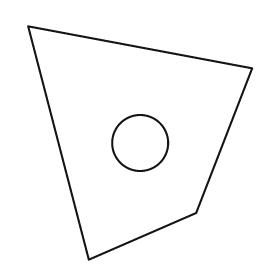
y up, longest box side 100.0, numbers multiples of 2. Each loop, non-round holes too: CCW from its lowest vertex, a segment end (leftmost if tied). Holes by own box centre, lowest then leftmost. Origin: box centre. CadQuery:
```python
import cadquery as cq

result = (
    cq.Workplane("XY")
    .moveTo(-22.0, -50.0)
    .lineTo(24.0, -30.0)
    .lineTo(48.0, 32.0)
    .lineTo(-48.0, 50.0)
    .close()
    .moveTo(0.0, 0.0)
    .circle(12.0)
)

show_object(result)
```